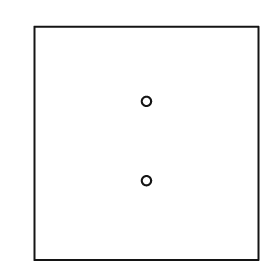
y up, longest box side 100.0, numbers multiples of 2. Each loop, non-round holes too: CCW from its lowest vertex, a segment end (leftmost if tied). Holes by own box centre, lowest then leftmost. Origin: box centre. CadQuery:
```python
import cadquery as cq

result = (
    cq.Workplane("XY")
    .moveTo(-48.0, -50.0)
    .lineTo(48.0, -50.0)
    .lineTo(48.0, 50.0)
    .lineTo(-48.0, 50.0)
    .close()
    .moveTo(0.0, -16.0)
    .circle(2.0)
    .moveTo(0.0, 18.0)
    .circle(2.0)
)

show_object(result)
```